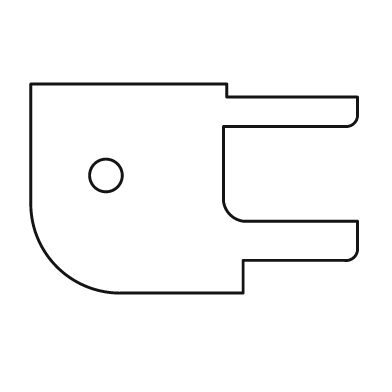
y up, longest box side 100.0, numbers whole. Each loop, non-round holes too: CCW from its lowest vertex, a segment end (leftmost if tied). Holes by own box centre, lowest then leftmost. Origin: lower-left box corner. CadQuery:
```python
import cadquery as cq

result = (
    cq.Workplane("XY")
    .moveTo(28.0, 0.0)
    .lineTo(65.0, 0.0)
    .lineTo(65.0, 10.0)
    .lineTo(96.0, 10.0)
    .threePointArc((99.0, 11.0), (100.0, 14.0))
    .lineTo(100.0, 22.0)
    .lineTo(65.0, 22.0)
    .threePointArc((61.0, 24.0), (59.0, 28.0))
    .lineTo(59.0, 51.0)
    .lineTo(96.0, 51.0)
    .threePointArc((99.0, 52.0), (100.0, 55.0))
    .lineTo(100.0, 60.0)
    .lineTo(60.0, 60.0)
    .lineTo(60.0, 64.0)
    .lineTo(0.0, 64.0)
    .lineTo(0.0, 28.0)
    .threePointArc((8.0, 8.0), (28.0, 0.0))
    .close()
    .moveTo(23.0, 36.0)
    .circle(5.0)
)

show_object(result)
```